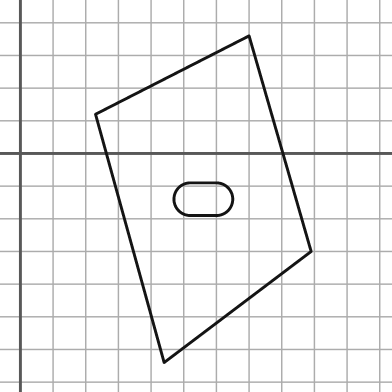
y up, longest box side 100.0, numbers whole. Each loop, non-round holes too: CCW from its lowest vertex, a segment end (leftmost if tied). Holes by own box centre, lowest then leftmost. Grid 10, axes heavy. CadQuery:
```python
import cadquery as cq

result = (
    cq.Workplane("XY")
    .moveTo(44.0, -64.0)
    .lineTo(89.0, -30.0)
    .lineTo(70.0, 36.0)
    .lineTo(23.0, 12.0)
    .close()
    .moveTo(52.0, -19.0)
    .lineTo(60.0, -19.0)
    .threePointArc((65.0, -14.0), (60.0, -9.0))
    .lineTo(52.0, -9.0)
    .threePointArc((47.0, -14.0), (52.0, -19.0))
    .close()
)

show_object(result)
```